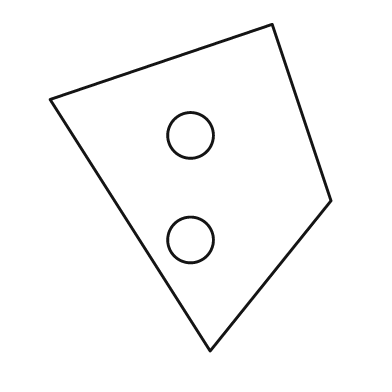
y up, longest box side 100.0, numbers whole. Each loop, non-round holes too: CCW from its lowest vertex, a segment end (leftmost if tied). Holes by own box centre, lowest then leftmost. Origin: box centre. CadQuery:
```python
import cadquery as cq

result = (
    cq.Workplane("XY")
    .moveTo(6.0, -50.0)
    .lineTo(43.0, -4.0)
    .lineTo(25.0, 50.0)
    .lineTo(-43.0, 27.0)
    .close()
    .moveTo(0.0, -16.0)
    .circle(7.0)
    .moveTo(0.0, 16.0)
    .circle(7.0)
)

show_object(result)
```